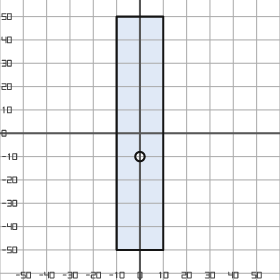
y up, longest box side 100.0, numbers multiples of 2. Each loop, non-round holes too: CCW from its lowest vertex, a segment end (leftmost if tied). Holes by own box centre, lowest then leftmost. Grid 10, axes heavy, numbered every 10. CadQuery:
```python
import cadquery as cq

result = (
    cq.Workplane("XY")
    .moveTo(-10.0, -50.0)
    .lineTo(10.0, -50.0)
    .lineTo(10.0, 50.0)
    .lineTo(-10.0, 50.0)
    .close()
    .moveTo(0.0, -10.0)
    .circle(2.0)
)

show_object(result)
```